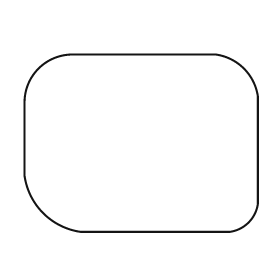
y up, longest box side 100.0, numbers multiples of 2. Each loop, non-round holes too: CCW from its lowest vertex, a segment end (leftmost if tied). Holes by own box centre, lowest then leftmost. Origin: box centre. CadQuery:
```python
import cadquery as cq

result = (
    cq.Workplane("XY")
    .moveTo(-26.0, -38.0)
    .lineTo(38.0, -38.0)
    .threePointArc((46.0, -34.0), (50.0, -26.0))
    .lineTo(50.0, 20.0)
    .threePointArc((44.0, 32.0), (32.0, 38.0))
    .lineTo(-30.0, 38.0)
    .threePointArc((-44.0, 32.0), (-50.0, 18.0))
    .lineTo(-50.0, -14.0)
    .threePointArc((-42.0, -30.0), (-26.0, -38.0))
    .close()
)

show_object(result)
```